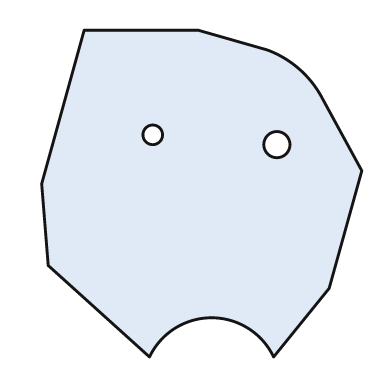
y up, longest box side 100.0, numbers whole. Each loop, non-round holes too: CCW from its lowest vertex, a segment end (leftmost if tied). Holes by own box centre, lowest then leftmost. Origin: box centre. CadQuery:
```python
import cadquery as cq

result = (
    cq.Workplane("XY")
    .moveTo(-16.0, -50.0)
    .threePointArc((3.0, -38.0), (22.0, -50.0))
    .lineTo(39.0, -29.0)
    .lineTo(49.0, 7.0)
    .lineTo(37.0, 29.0)
    .threePointArc((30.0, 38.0), (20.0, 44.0))
    .lineTo(-1.0, 50.0)
    .lineTo(-36.0, 50.0)
    .lineTo(-49.0, 3.0)
    .lineTo(-47.0, -22.0)
    .close()
    .moveTo(23.0, 15.0)
    .circle(4.0)
    .moveTo(-15.0, 18.0)
    .circle(3.0)
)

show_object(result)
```